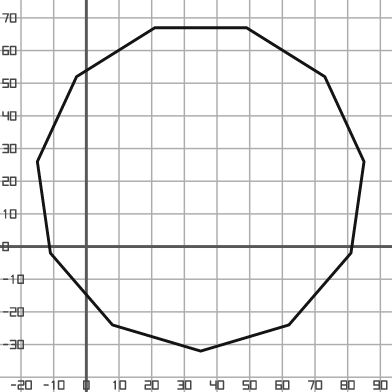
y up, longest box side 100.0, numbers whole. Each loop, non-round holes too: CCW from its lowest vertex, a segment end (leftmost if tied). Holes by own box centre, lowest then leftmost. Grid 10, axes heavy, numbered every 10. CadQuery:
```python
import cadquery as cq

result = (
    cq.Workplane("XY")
    .moveTo(35.0, -32.0)
    .lineTo(62.0, -24.0)
    .lineTo(81.0, -2.0)
    .lineTo(85.0, 26.0)
    .lineTo(73.0, 52.0)
    .lineTo(49.0, 67.0)
    .lineTo(21.0, 67.0)
    .lineTo(-3.0, 52.0)
    .lineTo(-15.0, 26.0)
    .lineTo(-11.0, -2.0)
    .lineTo(8.0, -24.0)
    .close()
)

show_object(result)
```